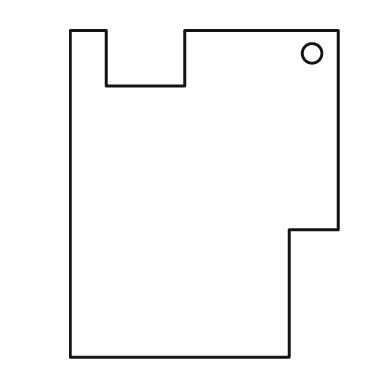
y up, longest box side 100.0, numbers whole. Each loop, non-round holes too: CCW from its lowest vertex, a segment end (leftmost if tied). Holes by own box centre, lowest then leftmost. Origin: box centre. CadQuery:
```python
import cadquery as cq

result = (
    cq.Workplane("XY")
    .moveTo(-41.0, -50.0)
    .lineTo(26.0, -50.0)
    .lineTo(26.0, -11.0)
    .lineTo(41.0, -11.0)
    .lineTo(41.0, 50.0)
    .lineTo(-6.0, 50.0)
    .lineTo(-6.0, 33.0)
    .lineTo(-30.0, 33.0)
    .lineTo(-30.0, 50.0)
    .lineTo(-41.0, 50.0)
    .close()
    .moveTo(33.0, 43.0)
    .circle(3.0)
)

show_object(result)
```